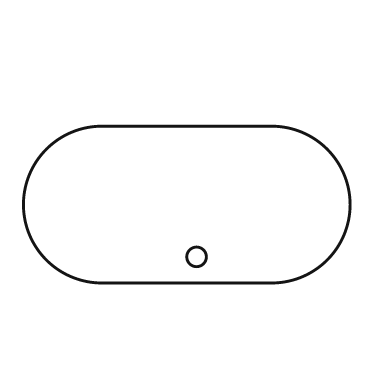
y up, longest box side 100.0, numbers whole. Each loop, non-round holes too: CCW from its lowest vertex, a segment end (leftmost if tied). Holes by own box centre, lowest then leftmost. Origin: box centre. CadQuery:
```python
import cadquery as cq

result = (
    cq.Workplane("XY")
    .moveTo(-26.0, -24.0)
    .lineTo(26.0, -24.0)
    .threePointArc((50.0, 0.0), (26.0, 24.0))
    .lineTo(-26.0, 24.0)
    .threePointArc((-50.0, 0.0), (-26.0, -24.0))
    .close()
    .moveTo(3.0, -16.0)
    .circle(3.0)
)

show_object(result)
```